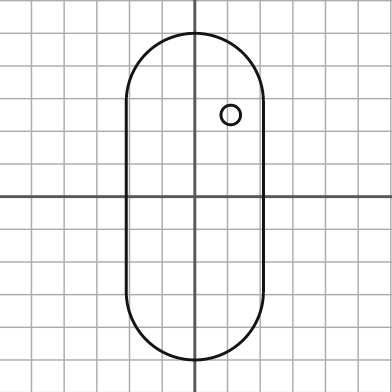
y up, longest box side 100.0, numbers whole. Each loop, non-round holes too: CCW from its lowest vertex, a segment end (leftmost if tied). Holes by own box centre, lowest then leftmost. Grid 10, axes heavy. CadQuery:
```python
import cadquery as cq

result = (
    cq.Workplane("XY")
    .moveTo(-21.0, -29.0)
    .threePointArc((0.0, -50.0), (21.0, -29.0))
    .lineTo(21.0, 29.0)
    .threePointArc((0.0, 50.0), (-21.0, 29.0))
    .close()
    .moveTo(11.0, 25.0)
    .circle(3.0)
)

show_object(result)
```